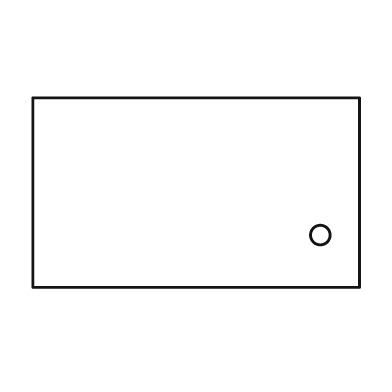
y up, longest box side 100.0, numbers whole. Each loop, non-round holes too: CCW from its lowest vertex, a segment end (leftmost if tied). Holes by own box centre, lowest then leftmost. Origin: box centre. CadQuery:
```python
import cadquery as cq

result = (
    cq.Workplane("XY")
    .moveTo(-50.0, -29.0)
    .lineTo(50.0, -29.0)
    .lineTo(50.0, 29.0)
    .lineTo(-50.0, 29.0)
    .close()
    .moveTo(38.0, -13.0)
    .circle(3.0)
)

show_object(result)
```